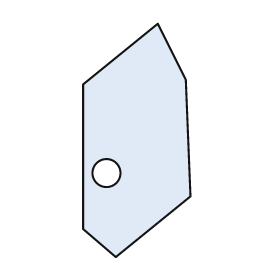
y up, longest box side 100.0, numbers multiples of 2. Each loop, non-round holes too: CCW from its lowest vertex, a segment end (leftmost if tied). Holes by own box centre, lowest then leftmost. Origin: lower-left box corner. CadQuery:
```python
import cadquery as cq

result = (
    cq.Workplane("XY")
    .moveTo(14.0, 0.0)
    .lineTo(46.0, 26.0)
    .lineTo(44.0, 76.0)
    .lineTo(32.0, 100.0)
    .lineTo(0.0, 74.0)
    .lineTo(0.0, 12.0)
    .close()
    .moveTo(10.0, 36.0)
    .circle(6.0)
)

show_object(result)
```